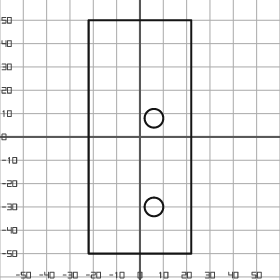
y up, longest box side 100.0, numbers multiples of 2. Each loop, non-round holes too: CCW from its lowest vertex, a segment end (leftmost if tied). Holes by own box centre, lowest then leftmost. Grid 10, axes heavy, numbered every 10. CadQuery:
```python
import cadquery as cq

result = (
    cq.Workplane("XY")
    .moveTo(-22.0, -50.0)
    .lineTo(22.0, -50.0)
    .lineTo(22.0, 50.0)
    .lineTo(-22.0, 50.0)
    .close()
    .moveTo(6.0, -30.0)
    .circle(4.0)
    .moveTo(6.0, 8.0)
    .circle(4.0)
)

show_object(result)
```